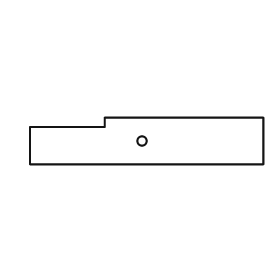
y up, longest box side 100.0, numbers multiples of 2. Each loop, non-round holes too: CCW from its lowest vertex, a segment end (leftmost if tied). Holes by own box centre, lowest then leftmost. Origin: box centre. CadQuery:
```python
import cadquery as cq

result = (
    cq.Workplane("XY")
    .moveTo(-50.0, -10.0)
    .lineTo(50.0, -10.0)
    .lineTo(50.0, 10.0)
    .lineTo(-18.0, 10.0)
    .lineTo(-18.0, 6.0)
    .lineTo(-50.0, 6.0)
    .close()
    .moveTo(-2.0, 0.0)
    .circle(2.0)
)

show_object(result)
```